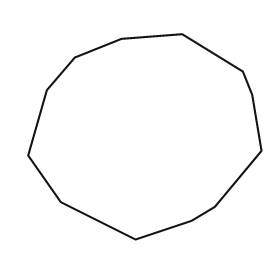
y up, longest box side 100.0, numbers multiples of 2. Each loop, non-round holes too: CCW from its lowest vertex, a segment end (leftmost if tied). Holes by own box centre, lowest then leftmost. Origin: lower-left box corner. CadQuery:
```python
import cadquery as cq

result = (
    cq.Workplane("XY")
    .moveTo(46.0, 0.0)
    .lineTo(70.0, 8.0)
    .lineTo(80.0, 14.0)
    .lineTo(100.0, 38.0)
    .lineTo(96.0, 62.0)
    .lineTo(92.0, 72.0)
    .lineTo(66.0, 88.0)
    .lineTo(40.0, 86.0)
    .lineTo(20.0, 78.0)
    .lineTo(8.0, 64.0)
    .lineTo(0.0, 36.0)
    .lineTo(14.0, 16.0)
    .close()
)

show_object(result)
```